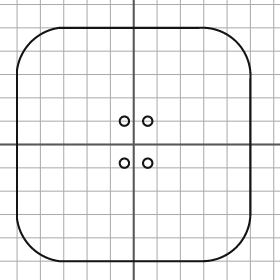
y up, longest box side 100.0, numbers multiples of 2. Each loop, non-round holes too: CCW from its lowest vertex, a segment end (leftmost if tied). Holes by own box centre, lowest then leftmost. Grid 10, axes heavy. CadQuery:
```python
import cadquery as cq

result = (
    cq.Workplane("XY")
    .moveTo(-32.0, -50.0)
    .lineTo(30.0, -50.0)
    .threePointArc((44.0, -44.0), (50.0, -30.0))
    .lineTo(50.0, 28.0)
    .threePointArc((44.0, 44.0), (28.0, 50.0))
    .lineTo(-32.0, 50.0)
    .threePointArc((-44.0, 44.0), (-50.0, 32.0))
    .lineTo(-50.0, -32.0)
    .threePointArc((-44.0, -44.0), (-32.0, -50.0))
    .close()
    .moveTo(-4.0, -8.0)
    .circle(2.0)
    .moveTo(6.0, -8.0)
    .circle(2.0)
    .moveTo(-4.0, 10.0)
    .circle(2.0)
    .moveTo(6.0, 10.0)
    .circle(2.0)
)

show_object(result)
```